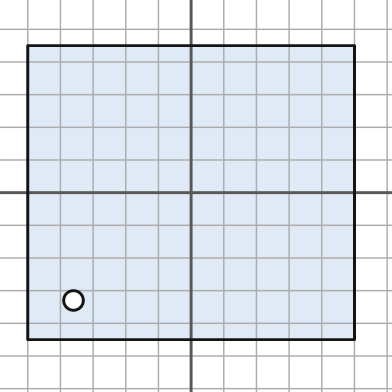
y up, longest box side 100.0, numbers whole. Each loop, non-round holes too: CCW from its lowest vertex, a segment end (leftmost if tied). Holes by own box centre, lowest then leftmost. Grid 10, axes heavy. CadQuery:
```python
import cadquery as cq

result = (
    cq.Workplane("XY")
    .moveTo(-50.0, -45.0)
    .lineTo(50.0, -45.0)
    .lineTo(50.0, 45.0)
    .lineTo(-50.0, 45.0)
    .close()
    .moveTo(-36.0, -33.0)
    .circle(3.0)
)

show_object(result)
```